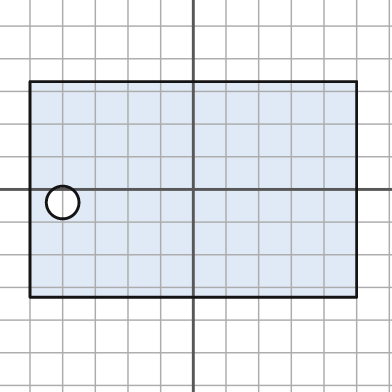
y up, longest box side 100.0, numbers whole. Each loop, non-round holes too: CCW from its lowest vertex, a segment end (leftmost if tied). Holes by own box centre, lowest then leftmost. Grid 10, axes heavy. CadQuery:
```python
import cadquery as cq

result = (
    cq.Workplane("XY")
    .moveTo(-50.0, -33.0)
    .lineTo(50.0, -33.0)
    .lineTo(50.0, 33.0)
    .lineTo(-50.0, 33.0)
    .close()
    .moveTo(-40.0, -4.0)
    .circle(5.0)
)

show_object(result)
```